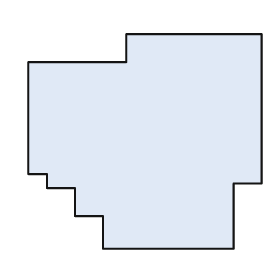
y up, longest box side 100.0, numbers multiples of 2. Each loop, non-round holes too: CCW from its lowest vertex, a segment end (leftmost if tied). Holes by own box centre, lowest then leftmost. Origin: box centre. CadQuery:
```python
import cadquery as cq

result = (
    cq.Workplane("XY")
    .moveTo(-18.0, -46.0)
    .lineTo(38.0, -46.0)
    .lineTo(38.0, -18.0)
    .lineTo(50.0, -18.0)
    .lineTo(50.0, 46.0)
    .lineTo(-8.0, 46.0)
    .lineTo(-8.0, 34.0)
    .lineTo(-50.0, 34.0)
    .lineTo(-50.0, -14.0)
    .lineTo(-42.0, -14.0)
    .lineTo(-42.0, -20.0)
    .lineTo(-30.0, -20.0)
    .lineTo(-30.0, -32.0)
    .lineTo(-18.0, -32.0)
    .close()
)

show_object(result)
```